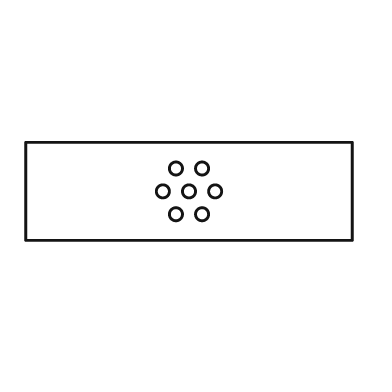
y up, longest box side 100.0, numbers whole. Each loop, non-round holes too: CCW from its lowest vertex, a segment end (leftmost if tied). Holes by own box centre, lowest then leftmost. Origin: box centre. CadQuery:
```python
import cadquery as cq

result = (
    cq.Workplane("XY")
    .moveTo(-50.0, -15.0)
    .lineTo(50.0, -15.0)
    .lineTo(50.0, 15.0)
    .lineTo(-50.0, 15.0)
    .close()
    .moveTo(-4.0, -7.0)
    .circle(2.0)
    .moveTo(4.0, -7.0)
    .circle(2.0)
    .moveTo(-8.0, 0.0)
    .circle(2.0)
    .moveTo(0.0, 0.0)
    .circle(2.0)
    .moveTo(8.0, 0.0)
    .circle(2.0)
    .moveTo(-4.0, 7.0)
    .circle(2.0)
    .moveTo(4.0, 7.0)
    .circle(2.0)
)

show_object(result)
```